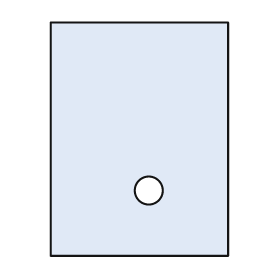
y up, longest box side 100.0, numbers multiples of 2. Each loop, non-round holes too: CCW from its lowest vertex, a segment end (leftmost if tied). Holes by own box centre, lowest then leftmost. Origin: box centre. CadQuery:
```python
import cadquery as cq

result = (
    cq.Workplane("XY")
    .moveTo(-38.0, -50.0)
    .lineTo(38.0, -50.0)
    .lineTo(38.0, 50.0)
    .lineTo(-38.0, 50.0)
    .close()
    .moveTo(4.0, -22.0)
    .circle(6.0)
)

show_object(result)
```